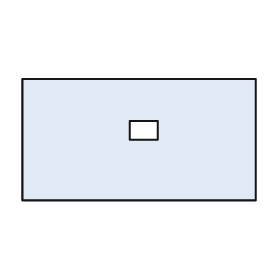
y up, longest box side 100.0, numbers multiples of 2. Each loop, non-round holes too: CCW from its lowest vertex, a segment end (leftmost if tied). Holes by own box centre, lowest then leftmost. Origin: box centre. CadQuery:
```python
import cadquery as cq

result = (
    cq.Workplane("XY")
    .moveTo(-50.0, -26.0)
    .lineTo(50.0, -26.0)
    .lineTo(50.0, 26.0)
    .lineTo(-50.0, 26.0)
    .close()
    .moveTo(-4.0, 0.0)
    .lineTo(8.0, 0.0)
    .lineTo(8.0, 8.0)
    .lineTo(-4.0, 8.0)
    .close()
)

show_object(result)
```